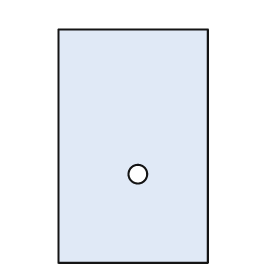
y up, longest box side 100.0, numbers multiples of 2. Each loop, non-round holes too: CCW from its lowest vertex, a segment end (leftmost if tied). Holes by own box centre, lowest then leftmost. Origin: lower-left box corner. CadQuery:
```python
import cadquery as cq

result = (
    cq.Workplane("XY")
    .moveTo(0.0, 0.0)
    .lineTo(64.0, 0.0)
    .lineTo(64.0, 100.0)
    .lineTo(0.0, 100.0)
    .close()
    .moveTo(34.0, 38.0)
    .circle(4.0)
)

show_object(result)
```